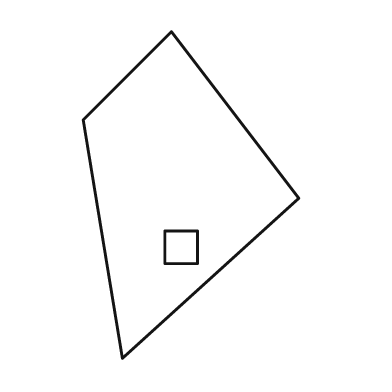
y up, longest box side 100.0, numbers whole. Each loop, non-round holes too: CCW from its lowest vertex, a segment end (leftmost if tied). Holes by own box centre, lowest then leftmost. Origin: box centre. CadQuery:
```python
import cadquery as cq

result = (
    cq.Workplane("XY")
    .moveTo(-21.0, -50.0)
    .lineTo(33.0, -1.0)
    .lineTo(-6.0, 50.0)
    .lineTo(-33.0, 23.0)
    .close()
    .moveTo(-8.0, -21.0)
    .lineTo(2.0, -21.0)
    .lineTo(2.0, -11.0)
    .lineTo(-8.0, -11.0)
    .close()
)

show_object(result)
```